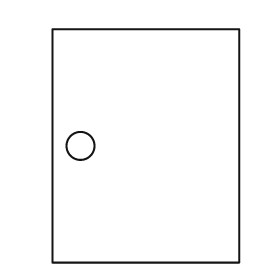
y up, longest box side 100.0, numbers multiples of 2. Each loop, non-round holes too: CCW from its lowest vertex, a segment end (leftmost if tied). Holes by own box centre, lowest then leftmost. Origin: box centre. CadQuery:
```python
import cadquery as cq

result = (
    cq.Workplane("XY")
    .moveTo(-40.0, -50.0)
    .lineTo(40.0, -50.0)
    .lineTo(40.0, 50.0)
    .lineTo(-40.0, 50.0)
    .close()
    .moveTo(-28.0, 0.0)
    .circle(6.0)
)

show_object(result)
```